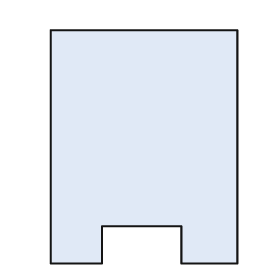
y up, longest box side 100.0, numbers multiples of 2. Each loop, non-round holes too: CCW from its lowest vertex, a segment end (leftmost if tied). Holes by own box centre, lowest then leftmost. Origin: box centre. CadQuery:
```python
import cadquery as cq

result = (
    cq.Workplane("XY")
    .moveTo(-40.0, -50.0)
    .lineTo(-18.0, -50.0)
    .lineTo(-18.0, -34.0)
    .lineTo(16.0, -34.0)
    .lineTo(16.0, -50.0)
    .lineTo(40.0, -50.0)
    .lineTo(40.0, 50.0)
    .lineTo(-40.0, 50.0)
    .close()
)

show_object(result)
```